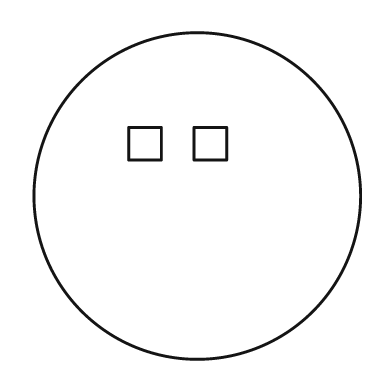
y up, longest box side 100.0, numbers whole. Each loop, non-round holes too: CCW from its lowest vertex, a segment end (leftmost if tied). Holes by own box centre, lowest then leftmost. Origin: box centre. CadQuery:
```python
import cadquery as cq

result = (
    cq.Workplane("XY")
    .moveTo(0.0, 0.0)
    .circle(50.0)
    .moveTo(-21.0, 11.0)
    .lineTo(-11.0, 11.0)
    .lineTo(-11.0, 21.0)
    .lineTo(-21.0, 21.0)
    .close()
    .moveTo(-1.0, 11.0)
    .lineTo(9.0, 11.0)
    .lineTo(9.0, 21.0)
    .lineTo(-1.0, 21.0)
    .close()
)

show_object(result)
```